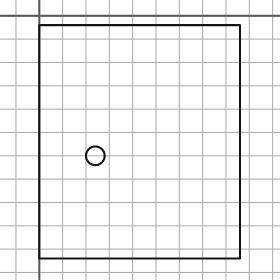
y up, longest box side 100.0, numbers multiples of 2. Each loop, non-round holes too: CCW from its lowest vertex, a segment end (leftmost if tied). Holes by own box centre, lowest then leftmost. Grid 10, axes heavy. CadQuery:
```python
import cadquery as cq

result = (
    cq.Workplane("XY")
    .moveTo(0.0, -104.0)
    .lineTo(86.0, -104.0)
    .lineTo(86.0, -4.0)
    .lineTo(0.0, -4.0)
    .close()
    .moveTo(24.0, -60.0)
    .circle(4.0)
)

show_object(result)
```